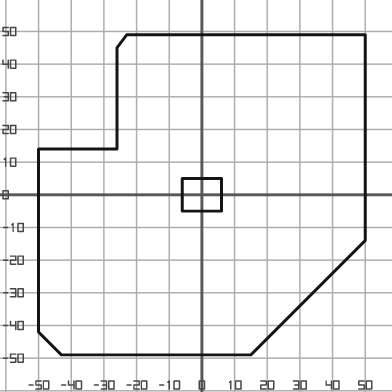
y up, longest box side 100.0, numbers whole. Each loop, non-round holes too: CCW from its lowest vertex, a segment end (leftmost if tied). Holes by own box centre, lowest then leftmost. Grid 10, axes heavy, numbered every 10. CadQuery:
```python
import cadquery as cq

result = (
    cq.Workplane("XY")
    .moveTo(-43.0, -49.0)
    .lineTo(15.0, -49.0)
    .lineTo(50.0, -14.0)
    .lineTo(50.0, 49.0)
    .lineTo(-23.0, 49.0)
    .lineTo(-26.0, 45.0)
    .lineTo(-26.0, 14.0)
    .lineTo(-50.0, 14.0)
    .lineTo(-50.0, -42.0)
    .close()
    .moveTo(-6.0, -5.0)
    .lineTo(6.0, -5.0)
    .lineTo(6.0, 5.0)
    .lineTo(-6.0, 5.0)
    .close()
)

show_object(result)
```